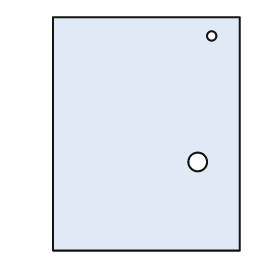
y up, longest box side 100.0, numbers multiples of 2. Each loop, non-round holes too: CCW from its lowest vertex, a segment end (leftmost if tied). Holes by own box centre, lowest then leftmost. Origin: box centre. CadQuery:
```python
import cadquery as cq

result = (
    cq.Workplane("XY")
    .moveTo(-40.0, -50.0)
    .lineTo(40.0, -50.0)
    .lineTo(40.0, 50.0)
    .lineTo(-40.0, 50.0)
    .close()
    .moveTo(22.0, -12.0)
    .circle(4.0)
    .moveTo(28.0, 42.0)
    .circle(2.0)
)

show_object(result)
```